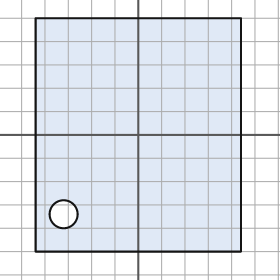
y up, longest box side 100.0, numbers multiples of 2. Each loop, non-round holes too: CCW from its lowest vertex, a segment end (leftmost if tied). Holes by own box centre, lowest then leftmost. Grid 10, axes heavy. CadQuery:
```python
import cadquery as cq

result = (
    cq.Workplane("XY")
    .moveTo(-44.0, -50.0)
    .lineTo(44.0, -50.0)
    .lineTo(44.0, 50.0)
    .lineTo(-44.0, 50.0)
    .close()
    .moveTo(-32.0, -34.0)
    .circle(6.0)
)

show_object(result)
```